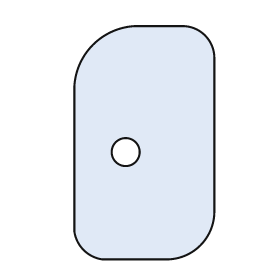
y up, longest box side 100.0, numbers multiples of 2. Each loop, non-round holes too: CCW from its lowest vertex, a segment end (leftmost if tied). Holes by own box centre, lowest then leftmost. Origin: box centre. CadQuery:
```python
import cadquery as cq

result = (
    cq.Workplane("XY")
    .moveTo(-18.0, -50.0)
    .lineTo(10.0, -50.0)
    .threePointArc((24.0, -44.0), (30.0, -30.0))
    .lineTo(30.0, 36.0)
    .threePointArc((26.0, 46.0), (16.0, 50.0))
    .lineTo(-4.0, 50.0)
    .threePointArc((-22.0, 42.0), (-30.0, 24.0))
    .lineTo(-30.0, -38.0)
    .threePointArc((-26.0, -46.0), (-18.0, -50.0))
    .close()
    .moveTo(-8.0, -4.0)
    .circle(6.0)
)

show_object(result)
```